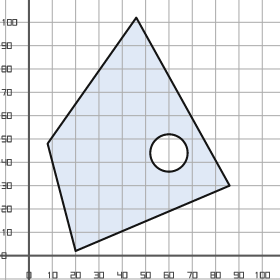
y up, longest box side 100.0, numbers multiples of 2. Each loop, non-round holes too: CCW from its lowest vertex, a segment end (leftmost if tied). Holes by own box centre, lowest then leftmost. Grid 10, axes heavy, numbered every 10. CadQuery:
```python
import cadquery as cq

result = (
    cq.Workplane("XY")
    .moveTo(20.0, 2.0)
    .lineTo(86.0, 30.0)
    .lineTo(46.0, 102.0)
    .lineTo(8.0, 48.0)
    .close()
    .moveTo(60.0, 44.0)
    .circle(8.0)
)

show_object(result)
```